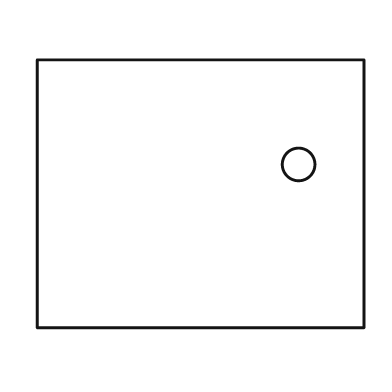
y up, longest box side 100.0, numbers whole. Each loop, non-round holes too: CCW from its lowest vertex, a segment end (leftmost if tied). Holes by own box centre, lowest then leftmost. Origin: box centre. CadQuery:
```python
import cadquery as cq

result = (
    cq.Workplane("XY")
    .moveTo(-50.0, -41.0)
    .lineTo(50.0, -41.0)
    .lineTo(50.0, 41.0)
    .lineTo(-50.0, 41.0)
    .close()
    .moveTo(30.0, 9.0)
    .circle(5.0)
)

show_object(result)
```